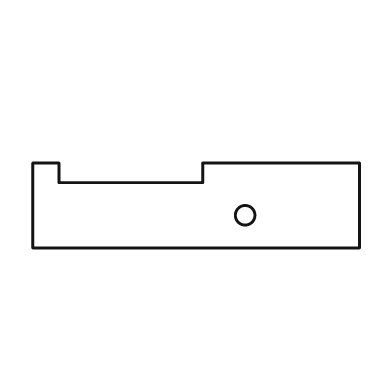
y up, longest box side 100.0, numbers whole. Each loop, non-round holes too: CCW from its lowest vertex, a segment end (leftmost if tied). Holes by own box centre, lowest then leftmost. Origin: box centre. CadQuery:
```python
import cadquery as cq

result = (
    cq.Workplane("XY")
    .moveTo(-50.0, -13.0)
    .lineTo(50.0, -13.0)
    .lineTo(50.0, 13.0)
    .lineTo(2.0, 13.0)
    .lineTo(2.0, 7.0)
    .lineTo(-42.0, 7.0)
    .lineTo(-42.0, 13.0)
    .lineTo(-50.0, 13.0)
    .close()
    .moveTo(15.0, -3.0)
    .circle(3.0)
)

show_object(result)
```